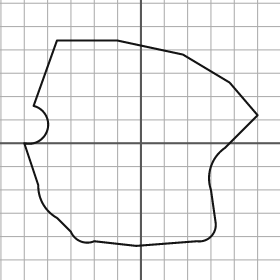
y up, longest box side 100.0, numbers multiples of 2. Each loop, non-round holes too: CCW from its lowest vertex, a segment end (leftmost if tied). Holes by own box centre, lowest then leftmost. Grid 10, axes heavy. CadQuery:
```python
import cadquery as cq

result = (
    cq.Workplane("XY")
    .moveTo(-2.0, -44.0)
    .lineTo(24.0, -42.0)
    .threePointArc((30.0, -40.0), (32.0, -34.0))
    .lineTo(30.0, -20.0)
    .threePointArc((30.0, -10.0), (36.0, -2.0))
    .lineTo(50.0, 12.0)
    .lineTo(38.0, 26.0)
    .lineTo(18.0, 38.0)
    .lineTo(-10.0, 44.0)
    .lineTo(-36.0, 44.0)
    .lineTo(-46.0, 16.0)
    .threePointArc((-40.0, 6.0), (-50.0, 0.0))
    .lineTo(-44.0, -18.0)
    .threePointArc((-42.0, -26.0), (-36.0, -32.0))
    .lineTo(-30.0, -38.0)
    .threePointArc((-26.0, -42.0), (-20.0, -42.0))
    .close()
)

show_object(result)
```